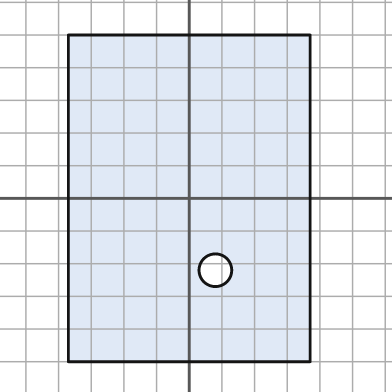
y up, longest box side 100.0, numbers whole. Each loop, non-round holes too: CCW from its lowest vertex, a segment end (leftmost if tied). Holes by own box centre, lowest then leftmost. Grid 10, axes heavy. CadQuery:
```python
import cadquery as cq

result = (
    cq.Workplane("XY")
    .moveTo(-37.0, -50.0)
    .lineTo(37.0, -50.0)
    .lineTo(37.0, 50.0)
    .lineTo(-37.0, 50.0)
    .close()
    .moveTo(8.0, -22.0)
    .circle(5.0)
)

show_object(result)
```